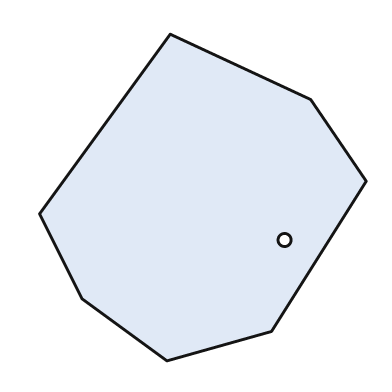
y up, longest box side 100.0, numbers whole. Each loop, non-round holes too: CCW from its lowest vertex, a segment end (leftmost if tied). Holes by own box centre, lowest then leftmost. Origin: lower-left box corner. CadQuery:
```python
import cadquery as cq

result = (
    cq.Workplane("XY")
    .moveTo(39.0, 0.0)
    .lineTo(71.0, 9.0)
    .lineTo(100.0, 55.0)
    .lineTo(83.0, 80.0)
    .lineTo(40.0, 100.0)
    .lineTo(0.0, 45.0)
    .lineTo(13.0, 19.0)
    .close()
    .moveTo(75.0, 37.0)
    .circle(2.0)
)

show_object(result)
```